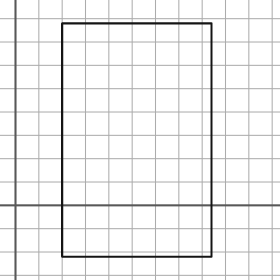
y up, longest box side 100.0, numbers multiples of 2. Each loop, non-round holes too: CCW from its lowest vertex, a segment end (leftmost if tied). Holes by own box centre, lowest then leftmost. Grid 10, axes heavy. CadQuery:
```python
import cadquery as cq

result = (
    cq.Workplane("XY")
    .moveTo(20.0, -22.0)
    .lineTo(84.0, -22.0)
    .lineTo(84.0, 78.0)
    .lineTo(20.0, 78.0)
    .close()
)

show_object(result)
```